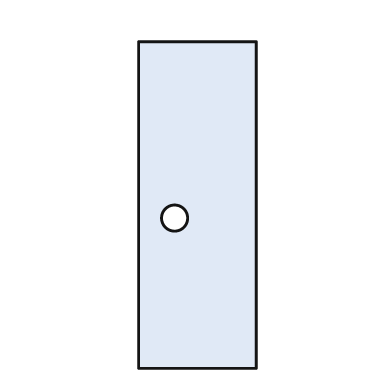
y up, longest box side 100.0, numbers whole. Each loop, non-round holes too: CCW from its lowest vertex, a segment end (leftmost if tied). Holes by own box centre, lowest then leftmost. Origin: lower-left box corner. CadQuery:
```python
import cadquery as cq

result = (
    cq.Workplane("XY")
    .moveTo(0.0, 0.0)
    .lineTo(36.0, 0.0)
    .lineTo(36.0, 100.0)
    .lineTo(0.0, 100.0)
    .close()
    .moveTo(11.0, 46.0)
    .circle(4.0)
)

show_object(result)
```